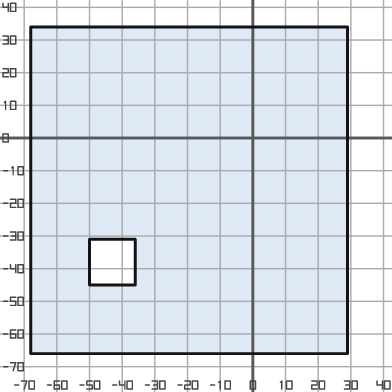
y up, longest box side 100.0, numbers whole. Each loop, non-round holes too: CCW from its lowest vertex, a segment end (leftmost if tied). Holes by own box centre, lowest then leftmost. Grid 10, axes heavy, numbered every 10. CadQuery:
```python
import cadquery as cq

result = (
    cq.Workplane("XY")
    .moveTo(-68.0, -66.0)
    .lineTo(29.0, -66.0)
    .lineTo(29.0, 34.0)
    .lineTo(-68.0, 34.0)
    .close()
    .moveTo(-50.0, -45.0)
    .lineTo(-36.0, -45.0)
    .lineTo(-36.0, -31.0)
    .lineTo(-50.0, -31.0)
    .close()
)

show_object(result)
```